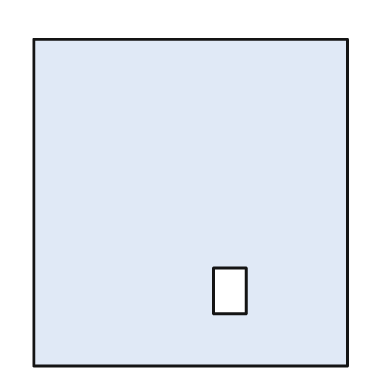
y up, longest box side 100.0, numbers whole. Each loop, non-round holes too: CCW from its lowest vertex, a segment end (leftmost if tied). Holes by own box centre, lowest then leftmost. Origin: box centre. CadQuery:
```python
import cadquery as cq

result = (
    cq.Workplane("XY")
    .moveTo(-48.0, -50.0)
    .lineTo(48.0, -50.0)
    .lineTo(48.0, 50.0)
    .lineTo(-48.0, 50.0)
    .close()
    .moveTo(7.0, -34.0)
    .lineTo(17.0, -34.0)
    .lineTo(17.0, -20.0)
    .lineTo(7.0, -20.0)
    .close()
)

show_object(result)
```